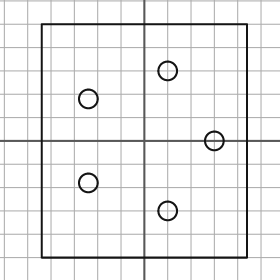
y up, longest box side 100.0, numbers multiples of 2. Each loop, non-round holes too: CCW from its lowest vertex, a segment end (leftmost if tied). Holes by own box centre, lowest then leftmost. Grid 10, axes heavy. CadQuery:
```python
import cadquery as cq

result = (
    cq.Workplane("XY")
    .moveTo(-44.0, -50.0)
    .lineTo(44.0, -50.0)
    .lineTo(44.0, 50.0)
    .lineTo(-44.0, 50.0)
    .close()
    .moveTo(10.0, -30.0)
    .circle(4.0)
    .moveTo(-24.0, -18.0)
    .circle(4.0)
    .moveTo(30.0, 0.0)
    .circle(4.0)
    .moveTo(-24.0, 18.0)
    .circle(4.0)
    .moveTo(10.0, 30.0)
    .circle(4.0)
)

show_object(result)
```